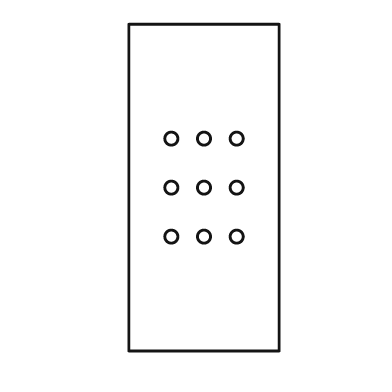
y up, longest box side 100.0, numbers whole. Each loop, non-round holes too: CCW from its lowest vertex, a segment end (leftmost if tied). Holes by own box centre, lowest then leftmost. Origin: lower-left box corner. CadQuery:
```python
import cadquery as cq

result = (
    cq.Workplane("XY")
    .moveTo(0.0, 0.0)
    .lineTo(46.0, 0.0)
    .lineTo(46.0, 100.0)
    .lineTo(0.0, 100.0)
    .close()
    .moveTo(13.0, 35.0)
    .circle(2.0)
    .moveTo(23.0, 35.0)
    .circle(2.0)
    .moveTo(33.0, 35.0)
    .circle(2.0)
    .moveTo(13.0, 50.0)
    .circle(2.0)
    .moveTo(23.0, 50.0)
    .circle(2.0)
    .moveTo(33.0, 50.0)
    .circle(2.0)
    .moveTo(13.0, 65.0)
    .circle(2.0)
    .moveTo(23.0, 65.0)
    .circle(2.0)
    .moveTo(33.0, 65.0)
    .circle(2.0)
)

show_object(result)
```